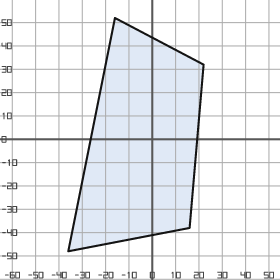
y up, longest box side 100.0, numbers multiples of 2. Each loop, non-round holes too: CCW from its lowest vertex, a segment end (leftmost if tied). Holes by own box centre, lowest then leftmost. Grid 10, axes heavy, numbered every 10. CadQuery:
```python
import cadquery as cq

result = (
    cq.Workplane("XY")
    .moveTo(-36.0, -48.0)
    .lineTo(16.0, -38.0)
    .lineTo(22.0, 32.0)
    .lineTo(-16.0, 52.0)
    .close()
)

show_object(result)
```